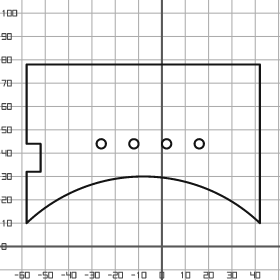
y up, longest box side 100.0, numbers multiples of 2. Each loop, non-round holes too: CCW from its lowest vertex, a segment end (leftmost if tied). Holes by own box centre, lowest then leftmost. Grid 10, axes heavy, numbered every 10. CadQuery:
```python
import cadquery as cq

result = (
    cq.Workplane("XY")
    .moveTo(-58.0, 10.0)
    .threePointArc((-8.0, 30.0), (42.0, 10.0))
    .lineTo(42.0, 78.0)
    .lineTo(-58.0, 78.0)
    .lineTo(-58.0, 44.0)
    .lineTo(-52.0, 44.0)
    .lineTo(-52.0, 32.0)
    .lineTo(-58.0, 32.0)
    .close()
    .moveTo(-26.0, 44.0)
    .circle(2.0)
    .moveTo(-12.0, 44.0)
    .circle(2.0)
    .moveTo(2.0, 44.0)
    .circle(2.0)
    .moveTo(16.0, 44.0)
    .circle(2.0)
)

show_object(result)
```